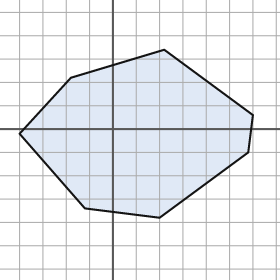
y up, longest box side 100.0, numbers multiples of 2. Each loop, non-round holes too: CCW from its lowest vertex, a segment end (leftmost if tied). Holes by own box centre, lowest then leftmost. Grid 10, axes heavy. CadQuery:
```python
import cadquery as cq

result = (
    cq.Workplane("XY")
    .moveTo(20.0, -38.0)
    .lineTo(58.0, -10.0)
    .lineTo(60.0, 6.0)
    .lineTo(22.0, 34.0)
    .lineTo(-18.0, 22.0)
    .lineTo(-40.0, -2.0)
    .lineTo(-12.0, -34.0)
    .close()
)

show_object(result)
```